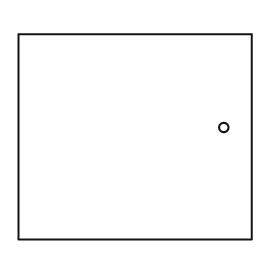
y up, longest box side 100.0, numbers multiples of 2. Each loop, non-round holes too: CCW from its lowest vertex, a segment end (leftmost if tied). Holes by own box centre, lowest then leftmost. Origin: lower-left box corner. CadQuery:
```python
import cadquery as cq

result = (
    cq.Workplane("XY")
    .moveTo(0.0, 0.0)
    .lineTo(100.0, 0.0)
    .lineTo(100.0, 88.0)
    .lineTo(0.0, 88.0)
    .close()
    .moveTo(88.0, 48.0)
    .circle(2.0)
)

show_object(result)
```